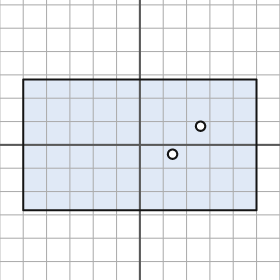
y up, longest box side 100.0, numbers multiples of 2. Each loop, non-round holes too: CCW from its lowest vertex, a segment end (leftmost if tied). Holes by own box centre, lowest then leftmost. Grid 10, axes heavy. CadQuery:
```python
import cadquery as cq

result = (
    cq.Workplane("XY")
    .moveTo(-50.0, -28.0)
    .lineTo(50.0, -28.0)
    .lineTo(50.0, 28.0)
    .lineTo(-50.0, 28.0)
    .close()
    .moveTo(14.0, -4.0)
    .circle(2.0)
    .moveTo(26.0, 8.0)
    .circle(2.0)
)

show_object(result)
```